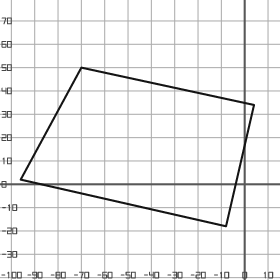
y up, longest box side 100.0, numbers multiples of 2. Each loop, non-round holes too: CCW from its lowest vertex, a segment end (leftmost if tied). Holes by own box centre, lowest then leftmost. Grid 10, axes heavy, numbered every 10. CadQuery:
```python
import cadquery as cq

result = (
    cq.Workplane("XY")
    .moveTo(-8.0, -18.0)
    .lineTo(4.0, 34.0)
    .lineTo(-70.0, 50.0)
    .lineTo(-96.0, 2.0)
    .close()
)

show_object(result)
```